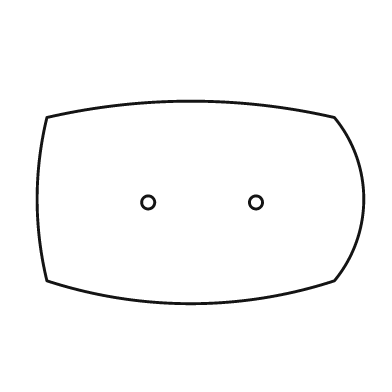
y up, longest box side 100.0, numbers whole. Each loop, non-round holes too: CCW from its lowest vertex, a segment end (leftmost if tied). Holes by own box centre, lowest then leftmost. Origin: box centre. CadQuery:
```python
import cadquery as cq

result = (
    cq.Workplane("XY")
    .moveTo(-47.0, -24.0)
    .threePointArc((-3.0, -31.0), (41.0, -24.0))
    .threePointArc((50.0, 1.0), (41.0, 26.0))
    .threePointArc((-3.0, 31.0), (-47.0, 26.0))
    .threePointArc((-50.0, 1.0), (-47.0, -24.0))
    .close()
    .moveTo(-16.0, 0.0)
    .circle(2.0)
    .moveTo(17.0, 0.0)
    .circle(2.0)
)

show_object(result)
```